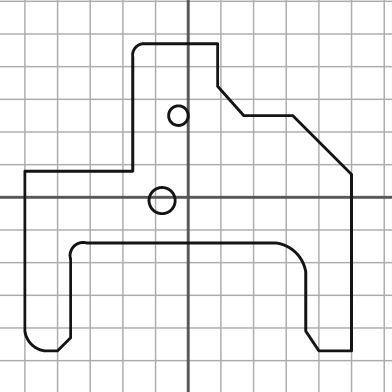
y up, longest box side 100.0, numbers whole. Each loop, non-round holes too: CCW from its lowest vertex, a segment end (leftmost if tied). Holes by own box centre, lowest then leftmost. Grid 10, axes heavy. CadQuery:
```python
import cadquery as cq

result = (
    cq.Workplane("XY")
    .moveTo(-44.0, -47.0)
    .lineTo(-40.0, -47.0)
    .lineTo(-36.0, -43.0)
    .lineTo(-36.0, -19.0)
    .threePointArc((-35.0, -15.0), (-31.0, -14.0))
    .lineTo(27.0, -14.0)
    .threePointArc((33.0, -17.0), (36.0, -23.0))
    .lineTo(36.0, -41.0)
    .lineTo(40.0, -47.0)
    .lineTo(50.0, -47.0)
    .lineTo(50.0, 7.0)
    .lineTo(32.0, 25.0)
    .lineTo(17.0, 25.0)
    .lineTo(9.0, 34.0)
    .lineTo(9.0, 47.0)
    .lineTo(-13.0, 47.0)
    .threePointArc((-16.0, 46.0), (-17.0, 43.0))
    .lineTo(-17.0, 8.0)
    .lineTo(-50.0, 8.0)
    .lineTo(-50.0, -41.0)
    .threePointArc((-48.0, -45.0), (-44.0, -47.0))
    .close()
    .moveTo(-8.0, -1.0)
    .circle(4.0)
    .moveTo(-3.0, 25.0)
    .circle(3.0)
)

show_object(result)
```